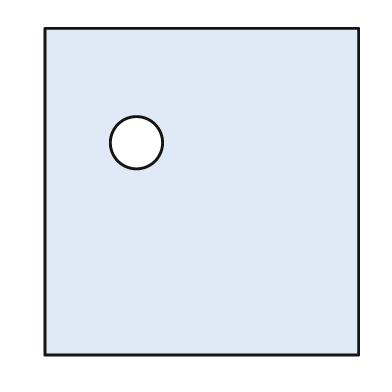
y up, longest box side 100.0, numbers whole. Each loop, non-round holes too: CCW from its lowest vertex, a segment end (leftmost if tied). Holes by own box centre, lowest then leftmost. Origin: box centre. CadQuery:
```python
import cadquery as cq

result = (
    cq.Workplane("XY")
    .moveTo(-48.0, -50.0)
    .lineTo(48.0, -50.0)
    .lineTo(48.0, 50.0)
    .lineTo(-48.0, 50.0)
    .close()
    .moveTo(-20.0, 15.0)
    .circle(8.0)
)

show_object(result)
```